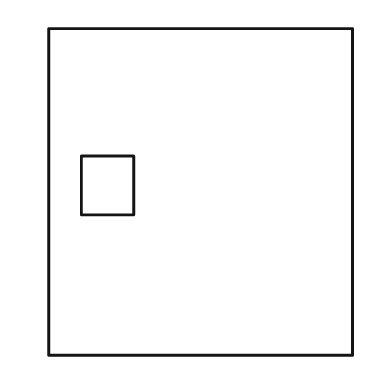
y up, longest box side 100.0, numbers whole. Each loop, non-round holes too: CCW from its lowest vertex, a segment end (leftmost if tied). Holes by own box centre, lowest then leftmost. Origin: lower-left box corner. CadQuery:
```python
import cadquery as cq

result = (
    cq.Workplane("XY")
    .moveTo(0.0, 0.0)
    .lineTo(93.0, 0.0)
    .lineTo(93.0, 100.0)
    .lineTo(0.0, 100.0)
    .close()
    .moveTo(10.0, 43.0)
    .lineTo(26.0, 43.0)
    .lineTo(26.0, 61.0)
    .lineTo(10.0, 61.0)
    .close()
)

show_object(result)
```